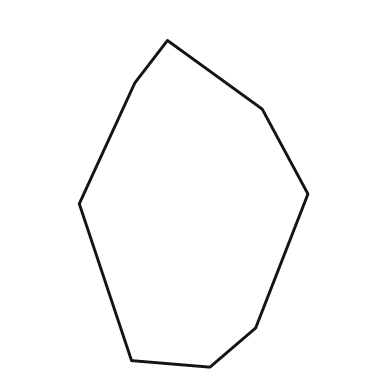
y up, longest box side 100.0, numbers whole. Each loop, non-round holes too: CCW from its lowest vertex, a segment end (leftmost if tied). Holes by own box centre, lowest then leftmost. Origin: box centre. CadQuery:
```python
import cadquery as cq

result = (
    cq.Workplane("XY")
    .moveTo(5.0, -50.0)
    .lineTo(19.0, -38.0)
    .lineTo(35.0, 3.0)
    .lineTo(21.0, 29.0)
    .lineTo(-8.0, 50.0)
    .lineTo(-18.0, 37.0)
    .lineTo(-35.0, 0.0)
    .lineTo(-19.0, -48.0)
    .close()
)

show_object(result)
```